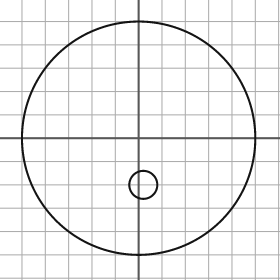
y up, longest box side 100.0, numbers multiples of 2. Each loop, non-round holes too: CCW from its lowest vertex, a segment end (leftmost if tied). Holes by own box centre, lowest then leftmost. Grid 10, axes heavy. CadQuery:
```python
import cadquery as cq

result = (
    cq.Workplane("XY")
    .moveTo(0.0, 0.0)
    .circle(50.0)
    .moveTo(2.0, -20.0)
    .circle(6.0)
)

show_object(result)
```